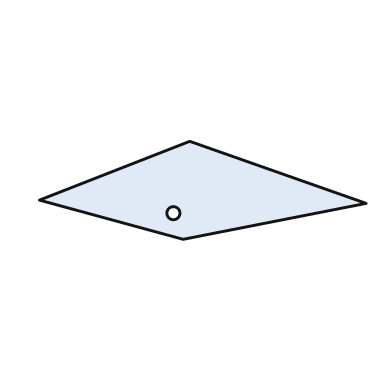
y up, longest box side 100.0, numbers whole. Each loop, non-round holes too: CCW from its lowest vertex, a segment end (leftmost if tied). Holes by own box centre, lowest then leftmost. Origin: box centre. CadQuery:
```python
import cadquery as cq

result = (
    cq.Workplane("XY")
    .moveTo(-6.0, -15.0)
    .lineTo(50.0, -4.0)
    .lineTo(-4.0, 15.0)
    .lineTo(-50.0, -3.0)
    .close()
    .moveTo(-9.0, -7.0)
    .circle(2.0)
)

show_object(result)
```